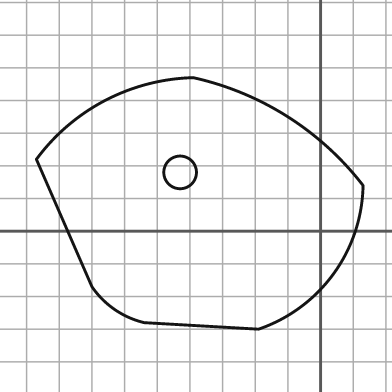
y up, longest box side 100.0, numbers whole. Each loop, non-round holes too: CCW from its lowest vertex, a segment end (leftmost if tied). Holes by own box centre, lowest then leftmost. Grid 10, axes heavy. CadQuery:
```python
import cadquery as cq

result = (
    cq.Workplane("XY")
    .moveTo(-19.0, -30.0)
    .threePointArc((4.0, -13.0), (13.0, 14.0))
    .threePointArc((-10.0, 35.0), (-39.0, 47.0))
    .threePointArc((-66.0, 40.0), (-87.0, 22.0))
    .lineTo(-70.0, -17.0)
    .threePointArc((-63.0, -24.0), (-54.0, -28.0))
    .close()
    .moveTo(-43.0, 18.0)
    .circle(5.0)
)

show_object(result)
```